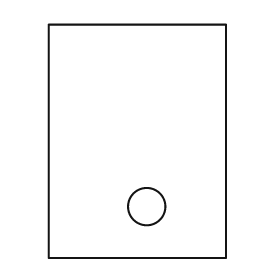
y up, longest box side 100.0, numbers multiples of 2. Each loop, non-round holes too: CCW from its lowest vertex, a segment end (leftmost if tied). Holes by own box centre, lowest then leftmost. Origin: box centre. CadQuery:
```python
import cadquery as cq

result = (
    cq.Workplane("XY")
    .moveTo(-38.0, -50.0)
    .lineTo(38.0, -50.0)
    .lineTo(38.0, 50.0)
    .lineTo(-38.0, 50.0)
    .close()
    .moveTo(4.0, -28.0)
    .circle(8.0)
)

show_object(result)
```